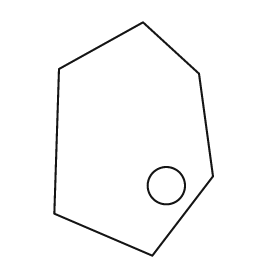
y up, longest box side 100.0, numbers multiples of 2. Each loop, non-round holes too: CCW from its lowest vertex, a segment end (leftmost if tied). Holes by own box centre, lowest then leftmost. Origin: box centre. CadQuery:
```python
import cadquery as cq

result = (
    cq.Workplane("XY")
    .moveTo(8.0, -50.0)
    .lineTo(34.0, -16.0)
    .lineTo(28.0, 28.0)
    .lineTo(4.0, 50.0)
    .lineTo(-32.0, 30.0)
    .lineTo(-34.0, -32.0)
    .close()
    .moveTo(14.0, -20.0)
    .circle(8.0)
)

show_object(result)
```